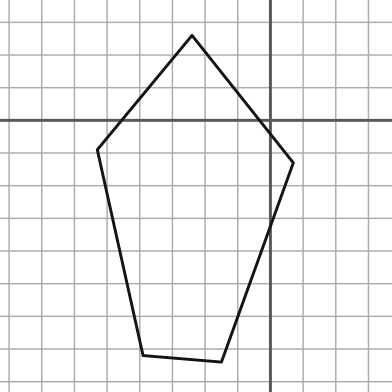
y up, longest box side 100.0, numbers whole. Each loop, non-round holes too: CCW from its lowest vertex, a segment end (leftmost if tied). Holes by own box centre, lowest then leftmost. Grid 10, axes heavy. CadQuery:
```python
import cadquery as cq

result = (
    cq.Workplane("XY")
    .moveTo(-15.0, -74.0)
    .lineTo(7.0, -13.0)
    .lineTo(-24.0, 26.0)
    .lineTo(-53.0, -9.0)
    .lineTo(-39.0, -72.0)
    .close()
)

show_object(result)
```